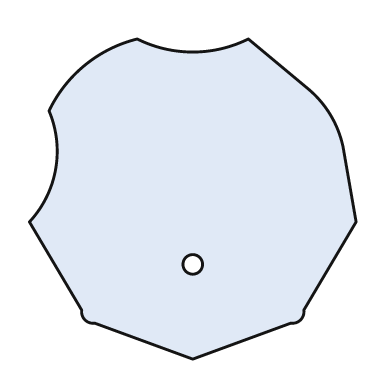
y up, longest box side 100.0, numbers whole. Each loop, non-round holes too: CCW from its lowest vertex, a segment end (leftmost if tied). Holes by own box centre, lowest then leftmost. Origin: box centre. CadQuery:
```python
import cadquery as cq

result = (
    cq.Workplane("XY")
    .moveTo(0.0, -49.0)
    .lineTo(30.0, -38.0)
    .threePointArc((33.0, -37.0), (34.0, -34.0))
    .lineTo(50.0, -7.0)
    .lineTo(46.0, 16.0)
    .threePointArc((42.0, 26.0), (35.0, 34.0))
    .lineTo(17.0, 49.0)
    .threePointArc((0.0, 45.0), (-17.0, 49.0))
    .threePointArc((-33.0, 41.0), (-44.0, 27.0))
    .threePointArc((-42.0, 9.0), (-50.0, -7.0))
    .lineTo(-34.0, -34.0)
    .threePointArc((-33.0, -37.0), (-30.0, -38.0))
    .close()
    .moveTo(0.0, -20.0)
    .circle(3.0)
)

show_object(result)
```